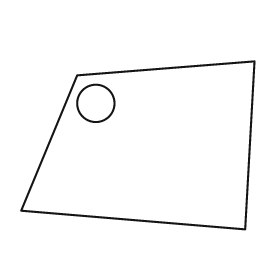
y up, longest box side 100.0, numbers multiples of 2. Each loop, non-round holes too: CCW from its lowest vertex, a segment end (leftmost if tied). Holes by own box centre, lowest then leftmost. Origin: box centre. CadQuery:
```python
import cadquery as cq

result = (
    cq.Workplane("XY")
    .moveTo(46.0, -36.0)
    .lineTo(50.0, 36.0)
    .lineTo(-26.0, 30.0)
    .lineTo(-50.0, -28.0)
    .close()
    .moveTo(-18.0, 18.0)
    .circle(8.0)
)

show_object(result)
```